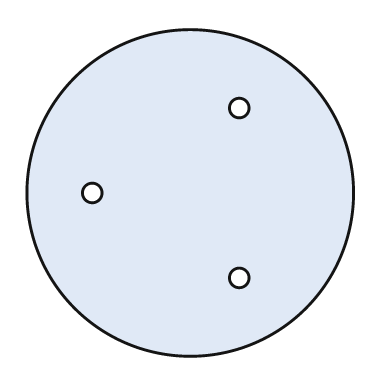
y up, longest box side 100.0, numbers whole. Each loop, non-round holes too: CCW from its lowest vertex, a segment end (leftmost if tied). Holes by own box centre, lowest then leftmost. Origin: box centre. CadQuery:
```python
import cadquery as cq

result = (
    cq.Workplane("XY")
    .moveTo(0.0, 0.0)
    .circle(50.0)
    .moveTo(15.0, -26.0)
    .circle(3.0)
    .moveTo(-30.0, 0.0)
    .circle(3.0)
    .moveTo(15.0, 26.0)
    .circle(3.0)
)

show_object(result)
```